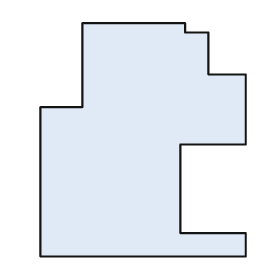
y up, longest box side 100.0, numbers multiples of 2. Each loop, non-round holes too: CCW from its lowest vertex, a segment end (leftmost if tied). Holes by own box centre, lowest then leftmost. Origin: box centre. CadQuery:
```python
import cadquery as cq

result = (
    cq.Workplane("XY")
    .moveTo(-44.0, -50.0)
    .lineTo(44.0, -50.0)
    .lineTo(44.0, -40.0)
    .lineTo(16.0, -40.0)
    .lineTo(16.0, -2.0)
    .lineTo(44.0, -2.0)
    .lineTo(44.0, 28.0)
    .lineTo(28.0, 28.0)
    .lineTo(28.0, 46.0)
    .lineTo(18.0, 46.0)
    .lineTo(18.0, 50.0)
    .lineTo(-26.0, 50.0)
    .lineTo(-26.0, 14.0)
    .lineTo(-44.0, 14.0)
    .close()
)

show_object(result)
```